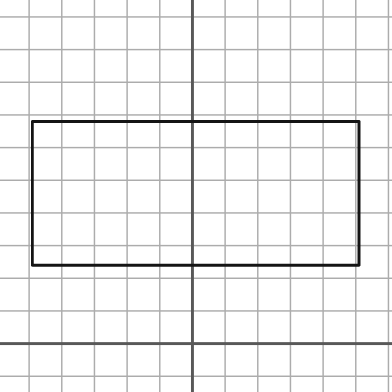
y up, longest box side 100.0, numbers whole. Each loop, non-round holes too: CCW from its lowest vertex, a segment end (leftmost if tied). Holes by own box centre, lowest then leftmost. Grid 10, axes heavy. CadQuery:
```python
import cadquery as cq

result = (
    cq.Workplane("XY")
    .moveTo(-49.0, 24.0)
    .lineTo(51.0, 24.0)
    .lineTo(51.0, 68.0)
    .lineTo(-49.0, 68.0)
    .close()
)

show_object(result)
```